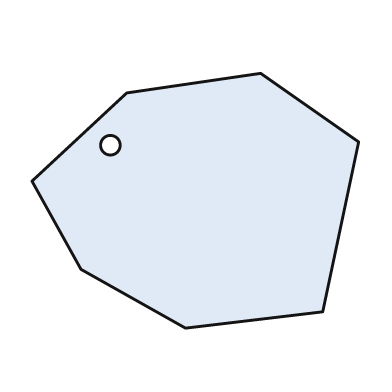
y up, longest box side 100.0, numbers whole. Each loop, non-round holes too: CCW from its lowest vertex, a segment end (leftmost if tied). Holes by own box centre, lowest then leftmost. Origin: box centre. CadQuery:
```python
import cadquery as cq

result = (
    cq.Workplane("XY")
    .moveTo(-3.0, -39.0)
    .lineTo(39.0, -34.0)
    .lineTo(50.0, 18.0)
    .lineTo(20.0, 39.0)
    .lineTo(-21.0, 33.0)
    .lineTo(-50.0, 6.0)
    .lineTo(-35.0, -21.0)
    .close()
    .moveTo(-26.0, 17.0)
    .circle(3.0)
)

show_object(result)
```